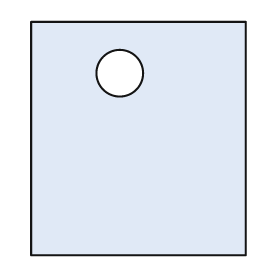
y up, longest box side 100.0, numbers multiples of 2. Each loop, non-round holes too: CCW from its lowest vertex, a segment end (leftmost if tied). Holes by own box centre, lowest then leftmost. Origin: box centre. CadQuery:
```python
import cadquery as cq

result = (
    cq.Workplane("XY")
    .moveTo(-46.0, -50.0)
    .lineTo(46.0, -50.0)
    .lineTo(46.0, 50.0)
    .lineTo(-46.0, 50.0)
    .close()
    .moveTo(-8.0, 28.0)
    .circle(10.0)
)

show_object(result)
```